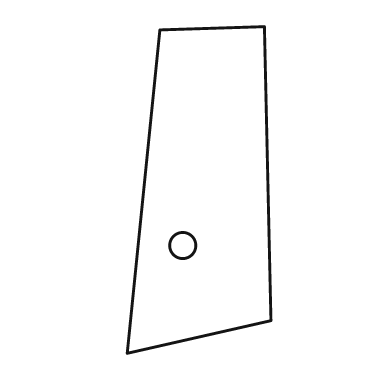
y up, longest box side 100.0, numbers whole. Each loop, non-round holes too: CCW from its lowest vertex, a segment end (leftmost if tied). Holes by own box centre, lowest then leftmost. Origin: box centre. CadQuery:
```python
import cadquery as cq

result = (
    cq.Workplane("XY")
    .moveTo(-22.0, -50.0)
    .lineTo(22.0, -40.0)
    .lineTo(20.0, 50.0)
    .lineTo(-12.0, 49.0)
    .close()
    .moveTo(-5.0, -17.0)
    .circle(4.0)
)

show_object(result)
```